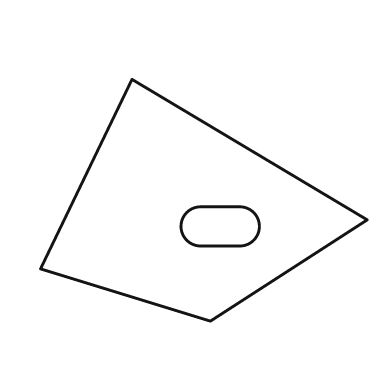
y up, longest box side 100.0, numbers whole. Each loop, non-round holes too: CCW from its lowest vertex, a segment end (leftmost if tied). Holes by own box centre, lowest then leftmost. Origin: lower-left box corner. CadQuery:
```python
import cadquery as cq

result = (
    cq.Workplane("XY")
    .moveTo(52.0, 0.0)
    .lineTo(100.0, 31.0)
    .lineTo(28.0, 74.0)
    .lineTo(0.0, 16.0)
    .close()
    .moveTo(49.0, 23.0)
    .lineTo(61.0, 23.0)
    .threePointArc((67.0, 29.0), (61.0, 35.0))
    .lineTo(49.0, 35.0)
    .threePointArc((43.0, 29.0), (49.0, 23.0))
    .close()
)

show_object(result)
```